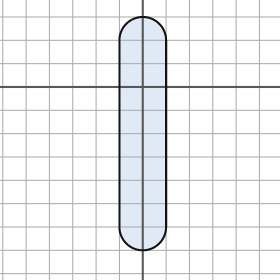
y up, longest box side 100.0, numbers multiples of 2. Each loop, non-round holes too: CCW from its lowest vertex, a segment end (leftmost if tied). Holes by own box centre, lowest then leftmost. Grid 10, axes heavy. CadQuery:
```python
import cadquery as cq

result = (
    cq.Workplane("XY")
    .moveTo(-10.0, -60.0)
    .threePointArc((0.0, -70.0), (10.0, -60.0))
    .lineTo(10.0, 20.0)
    .threePointArc((0.0, 30.0), (-10.0, 20.0))
    .close()
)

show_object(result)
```